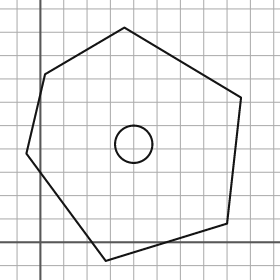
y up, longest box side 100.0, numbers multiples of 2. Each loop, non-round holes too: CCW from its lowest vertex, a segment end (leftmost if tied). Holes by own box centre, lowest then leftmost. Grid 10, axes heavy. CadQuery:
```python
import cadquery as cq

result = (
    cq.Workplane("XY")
    .moveTo(28.0, -8.0)
    .lineTo(80.0, 8.0)
    .lineTo(86.0, 62.0)
    .lineTo(36.0, 92.0)
    .lineTo(2.0, 72.0)
    .lineTo(-6.0, 38.0)
    .close()
    .moveTo(40.0, 42.0)
    .circle(8.0)
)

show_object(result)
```